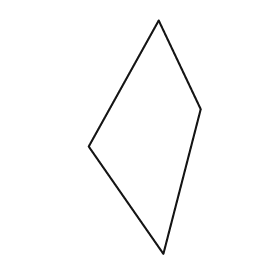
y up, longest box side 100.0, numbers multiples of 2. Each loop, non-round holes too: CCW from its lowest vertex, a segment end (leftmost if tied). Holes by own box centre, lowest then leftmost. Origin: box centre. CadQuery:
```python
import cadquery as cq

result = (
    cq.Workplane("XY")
    .moveTo(8.0, -50.0)
    .lineTo(24.0, 12.0)
    .lineTo(6.0, 50.0)
    .lineTo(-24.0, -4.0)
    .close()
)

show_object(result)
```